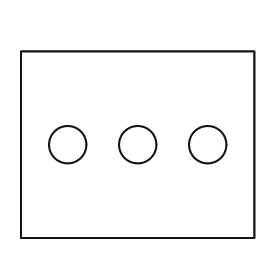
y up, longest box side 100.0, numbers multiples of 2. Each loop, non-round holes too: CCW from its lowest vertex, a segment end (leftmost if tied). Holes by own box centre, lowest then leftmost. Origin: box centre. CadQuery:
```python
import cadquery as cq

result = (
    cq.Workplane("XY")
    .moveTo(-50.0, -40.0)
    .lineTo(50.0, -40.0)
    .lineTo(50.0, 40.0)
    .lineTo(-50.0, 40.0)
    .close()
    .moveTo(-30.0, 0.0)
    .circle(8.0)
    .moveTo(0.0, 0.0)
    .circle(8.0)
    .moveTo(30.0, 0.0)
    .circle(8.0)
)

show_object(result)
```